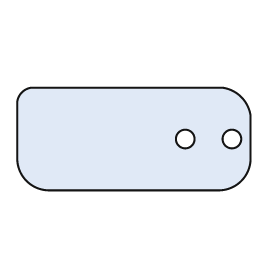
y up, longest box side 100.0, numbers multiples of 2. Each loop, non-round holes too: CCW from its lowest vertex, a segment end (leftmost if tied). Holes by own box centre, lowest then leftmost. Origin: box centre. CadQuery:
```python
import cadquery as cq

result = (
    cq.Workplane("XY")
    .moveTo(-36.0, -22.0)
    .lineTo(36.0, -22.0)
    .threePointArc((46.0, -18.0), (50.0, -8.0))
    .lineTo(50.0, 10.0)
    .threePointArc((46.0, 18.0), (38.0, 22.0))
    .lineTo(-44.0, 22.0)
    .threePointArc((-48.0, 20.0), (-50.0, 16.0))
    .lineTo(-50.0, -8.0)
    .threePointArc((-46.0, -18.0), (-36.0, -22.0))
    .close()
    .moveTo(22.0, 0.0)
    .circle(4.0)
    .moveTo(42.0, 0.0)
    .circle(4.0)
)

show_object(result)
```